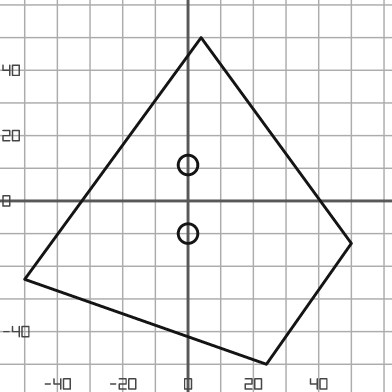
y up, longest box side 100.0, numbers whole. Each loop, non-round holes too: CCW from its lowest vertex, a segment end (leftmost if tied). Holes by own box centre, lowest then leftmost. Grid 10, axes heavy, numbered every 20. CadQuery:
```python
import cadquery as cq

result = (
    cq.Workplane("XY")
    .moveTo(24.0, -50.0)
    .lineTo(50.0, -13.0)
    .lineTo(4.0, 50.0)
    .lineTo(-50.0, -24.0)
    .close()
    .moveTo(0.0, -10.0)
    .circle(3.0)
    .moveTo(0.0, 11.0)
    .circle(3.0)
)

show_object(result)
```